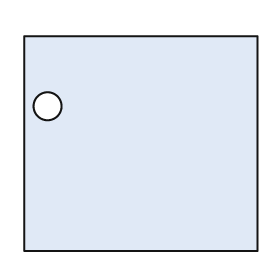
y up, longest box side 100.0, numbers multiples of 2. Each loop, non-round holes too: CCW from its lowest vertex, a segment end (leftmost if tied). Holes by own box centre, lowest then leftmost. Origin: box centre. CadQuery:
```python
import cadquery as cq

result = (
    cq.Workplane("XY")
    .moveTo(-50.0, -46.0)
    .lineTo(50.0, -46.0)
    .lineTo(50.0, 46.0)
    .lineTo(-50.0, 46.0)
    .close()
    .moveTo(-40.0, 16.0)
    .circle(6.0)
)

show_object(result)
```